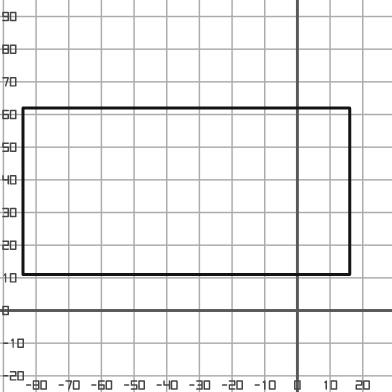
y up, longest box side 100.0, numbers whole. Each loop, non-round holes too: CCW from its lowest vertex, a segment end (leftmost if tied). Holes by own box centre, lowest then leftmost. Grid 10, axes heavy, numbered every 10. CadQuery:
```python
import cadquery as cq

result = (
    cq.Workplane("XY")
    .moveTo(-84.0, 11.0)
    .lineTo(16.0, 11.0)
    .lineTo(16.0, 62.0)
    .lineTo(-84.0, 62.0)
    .close()
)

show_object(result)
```